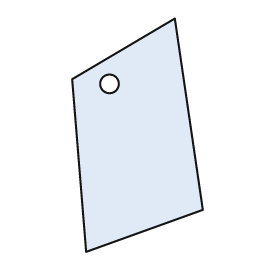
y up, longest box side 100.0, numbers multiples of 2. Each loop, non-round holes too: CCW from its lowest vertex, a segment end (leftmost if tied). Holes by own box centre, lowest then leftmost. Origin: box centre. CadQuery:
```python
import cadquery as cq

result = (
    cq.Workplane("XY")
    .moveTo(-22.0, -50.0)
    .lineTo(28.0, -32.0)
    .lineTo(16.0, 50.0)
    .lineTo(-28.0, 24.0)
    .close()
    .moveTo(-12.0, 22.0)
    .circle(4.0)
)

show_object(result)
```